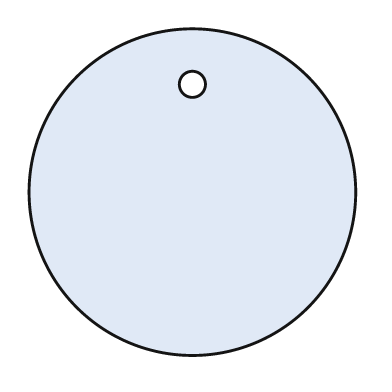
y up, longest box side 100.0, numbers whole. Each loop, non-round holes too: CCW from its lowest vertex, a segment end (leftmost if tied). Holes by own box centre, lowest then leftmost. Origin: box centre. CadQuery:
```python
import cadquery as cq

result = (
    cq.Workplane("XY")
    .moveTo(0.0, 0.0)
    .circle(50.0)
    .moveTo(0.0, 33.0)
    .circle(4.0)
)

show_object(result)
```